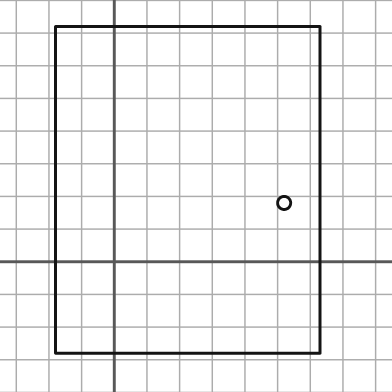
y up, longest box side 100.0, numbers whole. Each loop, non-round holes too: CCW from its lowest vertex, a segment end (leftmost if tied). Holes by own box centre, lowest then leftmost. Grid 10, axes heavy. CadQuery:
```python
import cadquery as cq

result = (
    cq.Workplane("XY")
    .moveTo(-18.0, -28.0)
    .lineTo(63.0, -28.0)
    .lineTo(63.0, 72.0)
    .lineTo(-18.0, 72.0)
    .close()
    .moveTo(52.0, 18.0)
    .circle(2.0)
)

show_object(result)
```